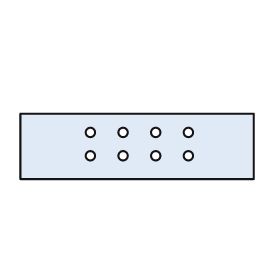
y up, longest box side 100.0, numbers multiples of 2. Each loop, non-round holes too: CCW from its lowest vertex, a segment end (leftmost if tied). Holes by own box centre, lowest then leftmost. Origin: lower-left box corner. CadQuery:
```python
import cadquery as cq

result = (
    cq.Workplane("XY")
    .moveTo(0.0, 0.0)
    .lineTo(100.0, 0.0)
    .lineTo(100.0, 28.0)
    .lineTo(0.0, 28.0)
    .close()
    .moveTo(30.0, 10.0)
    .circle(2.0)
    .moveTo(44.0, 10.0)
    .circle(2.0)
    .moveTo(58.0, 10.0)
    .circle(2.0)
    .moveTo(72.0, 10.0)
    .circle(2.0)
    .moveTo(30.0, 20.0)
    .circle(2.0)
    .moveTo(44.0, 20.0)
    .circle(2.0)
    .moveTo(58.0, 20.0)
    .circle(2.0)
    .moveTo(72.0, 20.0)
    .circle(2.0)
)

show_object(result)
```